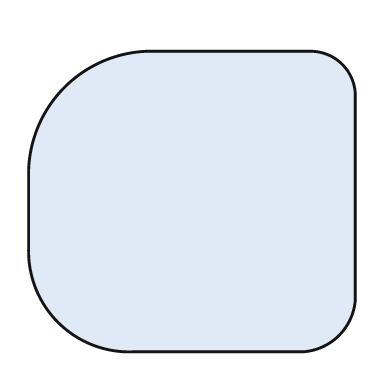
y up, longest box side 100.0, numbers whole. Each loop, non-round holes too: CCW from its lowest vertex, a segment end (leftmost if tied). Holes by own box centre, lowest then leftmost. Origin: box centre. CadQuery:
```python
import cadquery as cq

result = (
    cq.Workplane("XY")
    .moveTo(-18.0, -46.0)
    .lineTo(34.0, -46.0)
    .threePointArc((45.0, -41.0), (50.0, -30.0))
    .lineTo(50.0, 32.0)
    .threePointArc((46.0, 42.0), (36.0, 46.0))
    .lineTo(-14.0, 46.0)
    .threePointArc((-39.0, 35.0), (-50.0, 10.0))
    .lineTo(-50.0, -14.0)
    .threePointArc((-41.0, -37.0), (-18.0, -46.0))
    .close()
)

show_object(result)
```